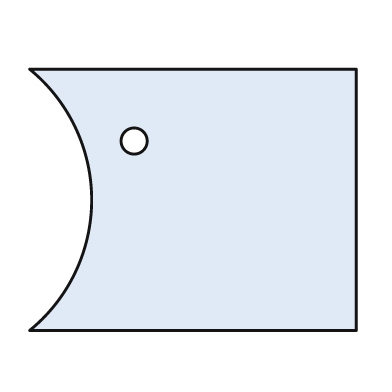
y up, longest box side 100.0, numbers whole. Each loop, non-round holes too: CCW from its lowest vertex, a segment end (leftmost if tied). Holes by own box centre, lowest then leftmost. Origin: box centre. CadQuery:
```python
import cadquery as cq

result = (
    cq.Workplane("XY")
    .moveTo(-50.0, -40.0)
    .lineTo(50.0, -40.0)
    .lineTo(50.0, 40.0)
    .lineTo(-50.0, 40.0)
    .threePointArc((-31.0, 0.0), (-50.0, -40.0))
    .close()
    .moveTo(-18.0, 18.0)
    .circle(4.0)
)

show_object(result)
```